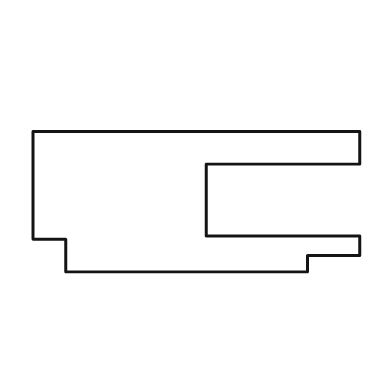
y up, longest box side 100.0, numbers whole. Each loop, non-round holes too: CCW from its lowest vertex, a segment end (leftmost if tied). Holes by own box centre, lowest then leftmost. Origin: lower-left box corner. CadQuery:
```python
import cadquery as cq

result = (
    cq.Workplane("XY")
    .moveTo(10.0, 0.0)
    .lineTo(84.0, 0.0)
    .lineTo(84.0, 5.0)
    .lineTo(100.0, 5.0)
    .lineTo(100.0, 11.0)
    .lineTo(53.0, 11.0)
    .lineTo(53.0, 33.0)
    .lineTo(100.0, 33.0)
    .lineTo(100.0, 43.0)
    .lineTo(0.0, 43.0)
    .lineTo(0.0, 10.0)
    .lineTo(10.0, 10.0)
    .close()
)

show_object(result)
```